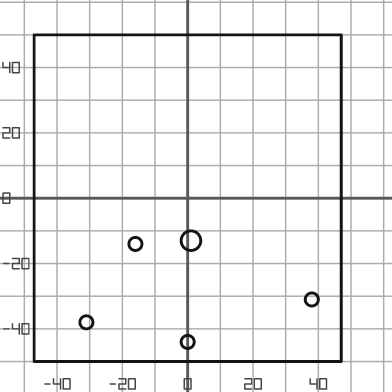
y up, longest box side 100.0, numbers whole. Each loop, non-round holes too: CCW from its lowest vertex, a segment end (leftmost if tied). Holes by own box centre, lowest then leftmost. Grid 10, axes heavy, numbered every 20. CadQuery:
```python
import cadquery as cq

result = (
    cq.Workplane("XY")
    .moveTo(-47.0, -50.0)
    .lineTo(47.0, -50.0)
    .lineTo(47.0, 50.0)
    .lineTo(-47.0, 50.0)
    .close()
    .moveTo(0.0, -44.0)
    .circle(2.0)
    .moveTo(-31.0, -38.0)
    .circle(2.0)
    .moveTo(38.0, -31.0)
    .circle(2.0)
    .moveTo(-16.0, -14.0)
    .circle(2.0)
    .moveTo(1.0, -13.0)
    .circle(3.0)
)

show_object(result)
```